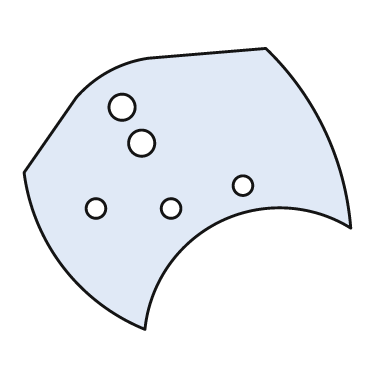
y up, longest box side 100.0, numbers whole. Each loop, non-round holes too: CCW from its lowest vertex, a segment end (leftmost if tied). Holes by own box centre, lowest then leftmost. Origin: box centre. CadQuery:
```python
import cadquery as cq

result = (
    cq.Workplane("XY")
    .moveTo(-13.0, -43.0)
    .threePointArc((10.0, -10.0), (50.0, -12.0))
    .threePointArc((42.0, 18.0), (24.0, 43.0))
    .lineTo(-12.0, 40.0)
    .threePointArc((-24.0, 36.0), (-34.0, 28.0))
    .lineTo(-50.0, 5.0)
    .threePointArc((-38.0, -24.0), (-13.0, -43.0))
    .close()
    .moveTo(-28.0, -6.0)
    .circle(3.0)
    .moveTo(-5.0, -6.0)
    .circle(3.0)
    .moveTo(17.0, 1.0)
    .circle(3.0)
    .moveTo(-14.0, 14.0)
    .circle(4.0)
    .moveTo(-20.0, 25.0)
    .circle(4.0)
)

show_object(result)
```